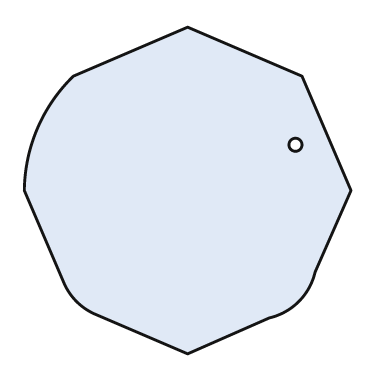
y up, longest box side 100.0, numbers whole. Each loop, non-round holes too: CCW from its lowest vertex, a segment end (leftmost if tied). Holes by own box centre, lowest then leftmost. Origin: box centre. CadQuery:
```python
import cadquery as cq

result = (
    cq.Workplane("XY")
    .moveTo(0.0, -50.0)
    .lineTo(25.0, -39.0)
    .threePointArc((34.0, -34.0), (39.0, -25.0))
    .lineTo(50.0, 0.0)
    .lineTo(35.0, 35.0)
    .lineTo(0.0, 50.0)
    .lineTo(-35.0, 35.0)
    .threePointArc((-46.0, 19.0), (-50.0, 0.0))
    .lineTo(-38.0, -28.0)
    .threePointArc((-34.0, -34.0), (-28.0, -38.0))
    .close()
    .moveTo(33.0, 14.0)
    .circle(2.0)
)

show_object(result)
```